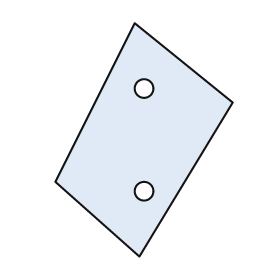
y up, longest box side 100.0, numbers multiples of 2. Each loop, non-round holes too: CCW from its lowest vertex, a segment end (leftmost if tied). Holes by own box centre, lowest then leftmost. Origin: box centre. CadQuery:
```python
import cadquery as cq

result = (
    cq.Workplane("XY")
    .moveTo(-2.0, -50.0)
    .lineTo(38.0, 16.0)
    .lineTo(-4.0, 50.0)
    .lineTo(-38.0, -18.0)
    .close()
    .moveTo(0.0, -22.0)
    .circle(4.0)
    .moveTo(0.0, 22.0)
    .circle(4.0)
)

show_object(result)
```